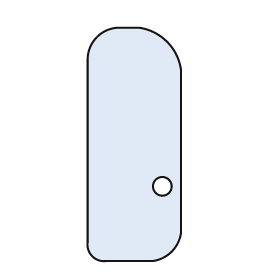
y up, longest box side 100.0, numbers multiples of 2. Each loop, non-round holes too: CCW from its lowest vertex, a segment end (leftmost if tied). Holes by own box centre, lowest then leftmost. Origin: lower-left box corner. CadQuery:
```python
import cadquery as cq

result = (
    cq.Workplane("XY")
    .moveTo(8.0, 0.0)
    .lineTo(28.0, 0.0)
    .threePointArc((36.0, 4.0), (40.0, 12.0))
    .lineTo(40.0, 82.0)
    .threePointArc((34.0, 94.0), (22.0, 100.0))
    .lineTo(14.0, 100.0)
    .threePointArc((4.0, 96.0), (0.0, 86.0))
    .lineTo(0.0, 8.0)
    .threePointArc((2.0, 2.0), (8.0, 0.0))
    .close()
    .moveTo(32.0, 32.0)
    .circle(4.0)
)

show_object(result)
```